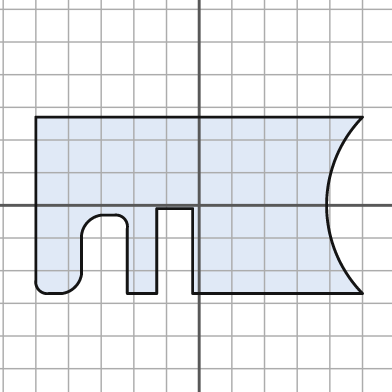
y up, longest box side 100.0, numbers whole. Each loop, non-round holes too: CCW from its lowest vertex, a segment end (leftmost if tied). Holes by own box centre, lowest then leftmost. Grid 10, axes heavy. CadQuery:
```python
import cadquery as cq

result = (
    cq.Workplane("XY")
    .moveTo(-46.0, -27.0)
    .lineTo(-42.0, -27.0)
    .threePointArc((-38.0, -25.0), (-36.0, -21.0))
    .lineTo(-36.0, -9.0)
    .threePointArc((-34.0, -5.0), (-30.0, -3.0))
    .lineTo(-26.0, -3.0)
    .threePointArc((-23.0, -4.0), (-22.0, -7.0))
    .lineTo(-22.0, -27.0)
    .lineTo(-13.0, -27.0)
    .lineTo(-13.0, -1.0)
    .lineTo(-2.0, -1.0)
    .lineTo(-2.0, -27.0)
    .lineTo(50.0, -27.0)
    .threePointArc((39.0, 0.0), (50.0, 27.0))
    .lineTo(-50.0, 27.0)
    .lineTo(-50.0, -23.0)
    .threePointArc((-49.0, -26.0), (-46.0, -27.0))
    .close()
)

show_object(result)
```